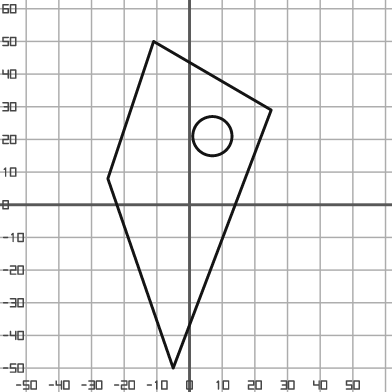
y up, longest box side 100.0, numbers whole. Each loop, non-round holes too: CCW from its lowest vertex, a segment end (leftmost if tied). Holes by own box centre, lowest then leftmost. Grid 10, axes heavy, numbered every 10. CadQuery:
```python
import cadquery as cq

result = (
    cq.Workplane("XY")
    .moveTo(-5.0, -50.0)
    .lineTo(25.0, 29.0)
    .lineTo(-11.0, 50.0)
    .lineTo(-25.0, 8.0)
    .close()
    .moveTo(7.0, 21.0)
    .circle(6.0)
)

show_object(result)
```